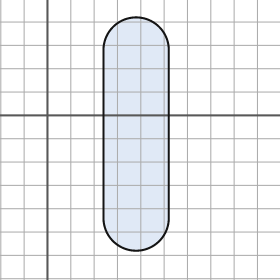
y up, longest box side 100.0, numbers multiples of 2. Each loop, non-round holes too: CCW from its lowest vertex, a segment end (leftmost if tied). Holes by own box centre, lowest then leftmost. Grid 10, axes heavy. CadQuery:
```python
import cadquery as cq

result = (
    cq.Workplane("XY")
    .moveTo(24.0, -44.0)
    .threePointArc((38.0, -58.0), (52.0, -44.0))
    .lineTo(52.0, 28.0)
    .threePointArc((38.0, 42.0), (24.0, 28.0))
    .close()
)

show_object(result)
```